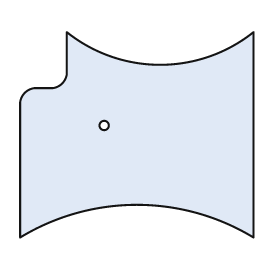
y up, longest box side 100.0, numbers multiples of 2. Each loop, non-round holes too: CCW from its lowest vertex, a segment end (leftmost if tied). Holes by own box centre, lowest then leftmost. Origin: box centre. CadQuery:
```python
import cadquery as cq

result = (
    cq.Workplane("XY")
    .moveTo(-50.0, -44.0)
    .threePointArc((0.0, -30.0), (50.0, -44.0))
    .lineTo(50.0, 44.0)
    .threePointArc((10.0, 30.0), (-30.0, 44.0))
    .lineTo(-30.0, 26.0)
    .threePointArc((-32.0, 22.0), (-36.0, 20.0))
    .lineTo(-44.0, 20.0)
    .threePointArc((-48.0, 18.0), (-50.0, 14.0))
    .close()
    .moveTo(-14.0, 4.0)
    .circle(2.0)
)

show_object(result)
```